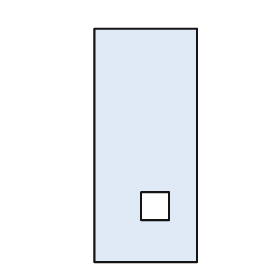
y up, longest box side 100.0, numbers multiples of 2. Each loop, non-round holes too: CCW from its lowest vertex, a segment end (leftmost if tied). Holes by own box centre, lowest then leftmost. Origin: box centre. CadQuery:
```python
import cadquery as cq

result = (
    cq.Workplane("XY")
    .moveTo(-22.0, -50.0)
    .lineTo(22.0, -50.0)
    .lineTo(22.0, 50.0)
    .lineTo(-22.0, 50.0)
    .close()
    .moveTo(-2.0, -32.0)
    .lineTo(10.0, -32.0)
    .lineTo(10.0, -20.0)
    .lineTo(-2.0, -20.0)
    .close()
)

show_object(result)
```